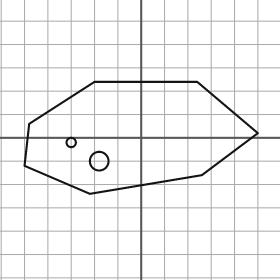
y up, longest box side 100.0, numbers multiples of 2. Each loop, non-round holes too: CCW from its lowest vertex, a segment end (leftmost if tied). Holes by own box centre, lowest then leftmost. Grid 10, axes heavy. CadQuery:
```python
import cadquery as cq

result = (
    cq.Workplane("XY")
    .moveTo(-22.0, -24.0)
    .lineTo(26.0, -16.0)
    .lineTo(50.0, 2.0)
    .lineTo(24.0, 24.0)
    .lineTo(-20.0, 24.0)
    .lineTo(-48.0, 6.0)
    .lineTo(-50.0, -12.0)
    .close()
    .moveTo(-18.0, -10.0)
    .circle(4.0)
    .moveTo(-30.0, -2.0)
    .circle(2.0)
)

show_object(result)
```